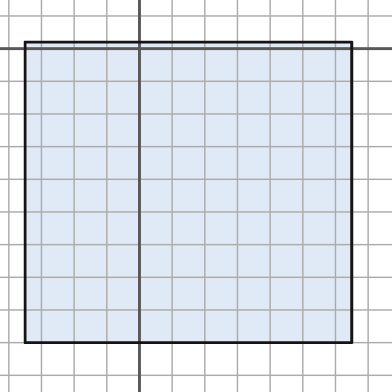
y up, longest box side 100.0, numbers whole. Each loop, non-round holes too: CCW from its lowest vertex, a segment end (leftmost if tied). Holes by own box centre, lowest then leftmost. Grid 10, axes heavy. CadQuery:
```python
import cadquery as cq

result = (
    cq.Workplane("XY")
    .moveTo(-35.0, -90.0)
    .lineTo(65.0, -90.0)
    .lineTo(65.0, 2.0)
    .lineTo(-35.0, 2.0)
    .close()
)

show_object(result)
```